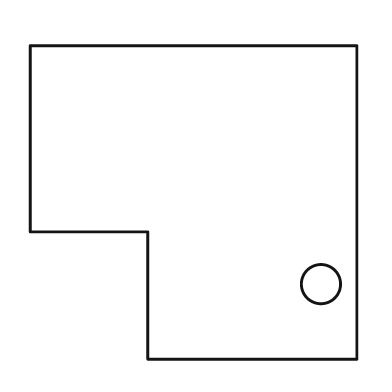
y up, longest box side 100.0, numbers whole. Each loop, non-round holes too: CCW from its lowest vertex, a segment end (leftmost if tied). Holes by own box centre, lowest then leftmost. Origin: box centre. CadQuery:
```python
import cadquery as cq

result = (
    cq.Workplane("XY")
    .moveTo(-14.0, -48.0)
    .lineTo(50.0, -48.0)
    .lineTo(50.0, 48.0)
    .lineTo(-50.0, 48.0)
    .lineTo(-50.0, -9.0)
    .lineTo(-14.0, -9.0)
    .close()
    .moveTo(39.0, -25.0)
    .circle(6.0)
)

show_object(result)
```